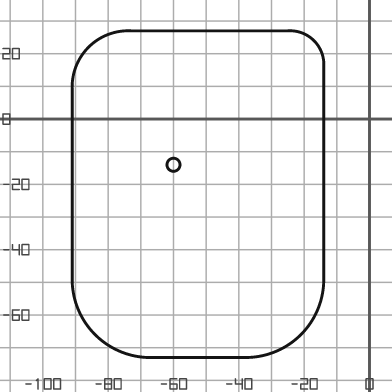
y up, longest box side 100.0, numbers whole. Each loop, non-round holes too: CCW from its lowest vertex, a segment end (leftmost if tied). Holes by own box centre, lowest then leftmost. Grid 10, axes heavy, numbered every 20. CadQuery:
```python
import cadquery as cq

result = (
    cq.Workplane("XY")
    .moveTo(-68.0, -73.0)
    .lineTo(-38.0, -73.0)
    .threePointArc((-21.0, -66.0), (-14.0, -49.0))
    .lineTo(-14.0, 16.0)
    .threePointArc((-17.0, 24.0), (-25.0, 27.0))
    .lineTo(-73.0, 27.0)
    .threePointArc((-86.0, 22.0), (-91.0, 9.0))
    .lineTo(-91.0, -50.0)
    .threePointArc((-84.0, -66.0), (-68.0, -73.0))
    .close()
    .moveTo(-60.0, -14.0)
    .circle(2.0)
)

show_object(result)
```